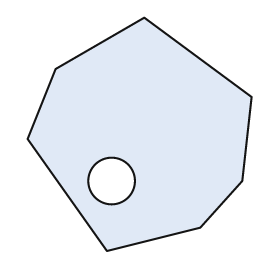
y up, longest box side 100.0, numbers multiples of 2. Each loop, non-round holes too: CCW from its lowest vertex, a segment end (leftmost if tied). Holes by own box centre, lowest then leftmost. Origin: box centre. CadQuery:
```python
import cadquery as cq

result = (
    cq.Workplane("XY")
    .moveTo(-14.0, -50.0)
    .lineTo(26.0, -40.0)
    .lineTo(44.0, -20.0)
    .lineTo(48.0, 16.0)
    .lineTo(2.0, 50.0)
    .lineTo(-36.0, 28.0)
    .lineTo(-48.0, -2.0)
    .close()
    .moveTo(-12.0, -20.0)
    .circle(10.0)
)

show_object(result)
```